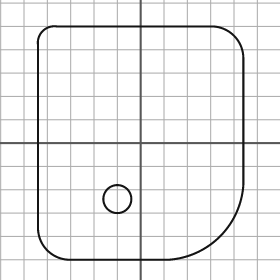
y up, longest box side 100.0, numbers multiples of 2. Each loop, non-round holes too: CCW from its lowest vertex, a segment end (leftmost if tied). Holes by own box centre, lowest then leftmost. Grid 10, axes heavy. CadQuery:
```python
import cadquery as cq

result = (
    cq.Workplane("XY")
    .moveTo(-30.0, -50.0)
    .lineTo(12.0, -50.0)
    .threePointArc((34.0, -40.0), (44.0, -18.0))
    .lineTo(44.0, 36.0)
    .threePointArc((40.0, 46.0), (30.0, 50.0))
    .lineTo(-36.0, 50.0)
    .threePointArc((-42.0, 48.0), (-44.0, 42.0))
    .lineTo(-44.0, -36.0)
    .threePointArc((-40.0, -46.0), (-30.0, -50.0))
    .close()
    .moveTo(-10.0, -24.0)
    .circle(6.0)
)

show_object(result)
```